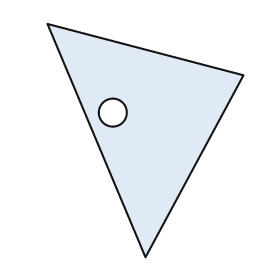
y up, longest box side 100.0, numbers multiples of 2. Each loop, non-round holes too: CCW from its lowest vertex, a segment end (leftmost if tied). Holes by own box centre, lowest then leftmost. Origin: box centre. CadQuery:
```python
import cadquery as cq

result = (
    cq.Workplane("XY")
    .moveTo(0.0, -50.0)
    .lineTo(42.0, 28.0)
    .lineTo(-42.0, 50.0)
    .close()
    .moveTo(-14.0, 12.0)
    .circle(6.0)
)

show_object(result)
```